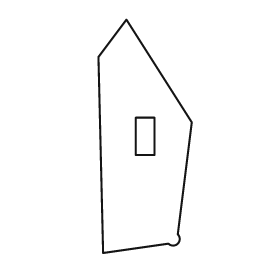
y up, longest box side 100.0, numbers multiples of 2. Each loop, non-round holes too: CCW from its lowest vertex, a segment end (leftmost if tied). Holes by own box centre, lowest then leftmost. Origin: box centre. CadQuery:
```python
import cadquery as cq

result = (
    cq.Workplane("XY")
    .moveTo(-18.0, -50.0)
    .lineTo(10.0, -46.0)
    .threePointArc((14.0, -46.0), (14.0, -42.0))
    .lineTo(20.0, 6.0)
    .lineTo(-8.0, 50.0)
    .lineTo(-20.0, 34.0)
    .close()
    .moveTo(-4.0, -8.0)
    .lineTo(4.0, -8.0)
    .lineTo(4.0, 8.0)
    .lineTo(-4.0, 8.0)
    .close()
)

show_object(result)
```